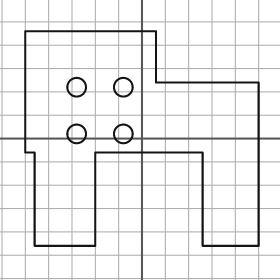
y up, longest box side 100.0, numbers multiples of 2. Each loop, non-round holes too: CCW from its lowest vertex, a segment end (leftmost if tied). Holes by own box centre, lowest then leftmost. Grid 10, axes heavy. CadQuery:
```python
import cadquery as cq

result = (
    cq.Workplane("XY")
    .moveTo(-46.0, -46.0)
    .lineTo(-20.0, -46.0)
    .lineTo(-20.0, -6.0)
    .lineTo(26.0, -6.0)
    .lineTo(26.0, -46.0)
    .lineTo(50.0, -46.0)
    .lineTo(50.0, 24.0)
    .lineTo(6.0, 24.0)
    .lineTo(6.0, 46.0)
    .lineTo(-50.0, 46.0)
    .lineTo(-50.0, -6.0)
    .lineTo(-46.0, -6.0)
    .close()
    .moveTo(-28.0, 2.0)
    .circle(4.0)
    .moveTo(-8.0, 2.0)
    .circle(4.0)
    .moveTo(-28.0, 22.0)
    .circle(4.0)
    .moveTo(-8.0, 22.0)
    .circle(4.0)
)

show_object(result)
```